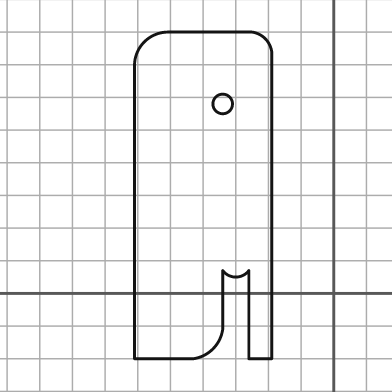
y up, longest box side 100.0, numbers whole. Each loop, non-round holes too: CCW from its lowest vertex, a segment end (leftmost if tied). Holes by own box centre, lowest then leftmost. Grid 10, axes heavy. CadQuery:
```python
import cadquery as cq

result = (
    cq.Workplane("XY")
    .moveTo(-61.0, -20.0)
    .lineTo(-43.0, -20.0)
    .threePointArc((-37.0, -17.0), (-34.0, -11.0))
    .lineTo(-34.0, 7.0)
    .threePointArc((-30.0, 5.0), (-26.0, 7.0))
    .lineTo(-26.0, -20.0)
    .lineTo(-19.0, -20.0)
    .lineTo(-19.0, 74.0)
    .threePointArc((-21.0, 78.0), (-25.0, 80.0))
    .lineTo(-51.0, 80.0)
    .threePointArc((-58.0, 77.0), (-61.0, 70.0))
    .close()
    .moveTo(-34.0, 58.0)
    .circle(3.0)
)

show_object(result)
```